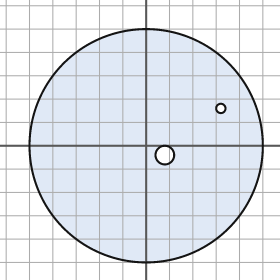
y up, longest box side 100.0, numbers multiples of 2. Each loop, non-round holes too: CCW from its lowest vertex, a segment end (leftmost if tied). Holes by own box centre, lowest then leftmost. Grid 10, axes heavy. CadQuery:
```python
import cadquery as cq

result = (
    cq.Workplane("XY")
    .moveTo(0.0, 0.0)
    .circle(50.0)
    .moveTo(8.0, -4.0)
    .circle(4.0)
    .moveTo(32.0, 16.0)
    .circle(2.0)
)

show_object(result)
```